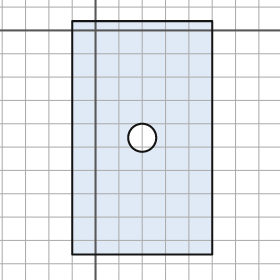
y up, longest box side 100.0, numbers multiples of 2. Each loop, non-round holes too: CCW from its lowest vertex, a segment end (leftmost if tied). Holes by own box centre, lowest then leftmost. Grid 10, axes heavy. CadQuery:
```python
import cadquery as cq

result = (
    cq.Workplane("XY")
    .moveTo(-10.0, -96.0)
    .lineTo(50.0, -96.0)
    .lineTo(50.0, 4.0)
    .lineTo(-10.0, 4.0)
    .close()
    .moveTo(20.0, -46.0)
    .circle(6.0)
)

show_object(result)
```